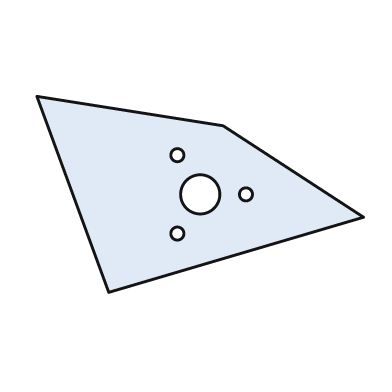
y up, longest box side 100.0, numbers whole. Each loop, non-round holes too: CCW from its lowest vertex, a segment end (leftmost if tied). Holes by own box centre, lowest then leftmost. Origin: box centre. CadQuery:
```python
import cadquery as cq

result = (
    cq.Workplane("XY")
    .moveTo(-28.0, -30.0)
    .lineTo(50.0, -7.0)
    .lineTo(7.0, 21.0)
    .lineTo(-50.0, 30.0)
    .close()
    .moveTo(-7.0, -12.0)
    .circle(2.0)
    .moveTo(0.0, 0.0)
    .circle(6.0)
    .moveTo(14.0, 0.0)
    .circle(2.0)
    .moveTo(-7.0, 12.0)
    .circle(2.0)
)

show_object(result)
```